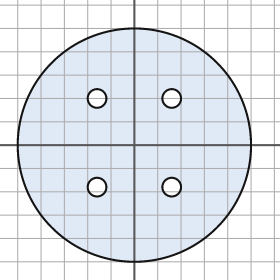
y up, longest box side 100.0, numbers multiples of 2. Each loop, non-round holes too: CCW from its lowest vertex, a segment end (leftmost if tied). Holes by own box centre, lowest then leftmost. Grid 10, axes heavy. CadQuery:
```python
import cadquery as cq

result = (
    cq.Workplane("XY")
    .moveTo(0.0, 0.0)
    .circle(50.0)
    .moveTo(-16.0, -18.0)
    .circle(4.0)
    .moveTo(16.0, -18.0)
    .circle(4.0)
    .moveTo(-16.0, 20.0)
    .circle(4.0)
    .moveTo(16.0, 20.0)
    .circle(4.0)
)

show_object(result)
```